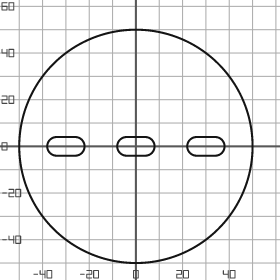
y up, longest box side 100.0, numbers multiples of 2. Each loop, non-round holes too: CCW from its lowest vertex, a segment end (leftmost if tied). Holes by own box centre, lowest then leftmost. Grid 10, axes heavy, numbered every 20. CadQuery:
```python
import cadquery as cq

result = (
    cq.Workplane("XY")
    .moveTo(0.0, 0.0)
    .circle(50.0)
    .moveTo(-34.0, -4.0)
    .lineTo(-26.0, -4.0)
    .threePointArc((-22.0, 0.0), (-26.0, 4.0))
    .lineTo(-34.0, 4.0)
    .threePointArc((-38.0, 0.0), (-34.0, -4.0))
    .close()
    .moveTo(-4.0, -4.0)
    .lineTo(4.0, -4.0)
    .threePointArc((8.0, 0.0), (4.0, 4.0))
    .lineTo(-4.0, 4.0)
    .threePointArc((-8.0, 0.0), (-4.0, -4.0))
    .close()
    .moveTo(26.0, -4.0)
    .lineTo(34.0, -4.0)
    .threePointArc((38.0, 0.0), (34.0, 4.0))
    .lineTo(26.0, 4.0)
    .threePointArc((22.0, 0.0), (26.0, -4.0))
    .close()
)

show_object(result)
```